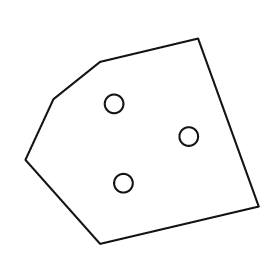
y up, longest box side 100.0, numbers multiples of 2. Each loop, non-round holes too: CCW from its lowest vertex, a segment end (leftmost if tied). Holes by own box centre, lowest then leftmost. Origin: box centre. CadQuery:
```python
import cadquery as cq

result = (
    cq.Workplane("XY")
    .moveTo(-18.0, -44.0)
    .lineTo(50.0, -28.0)
    .lineTo(24.0, 44.0)
    .lineTo(-18.0, 34.0)
    .lineTo(-38.0, 18.0)
    .lineTo(-50.0, -8.0)
    .close()
    .moveTo(-8.0, -18.0)
    .circle(4.0)
    .moveTo(20.0, 2.0)
    .circle(4.0)
    .moveTo(-12.0, 16.0)
    .circle(4.0)
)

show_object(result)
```